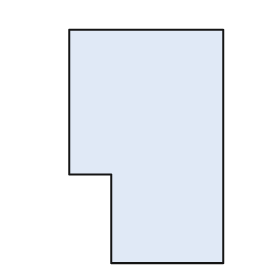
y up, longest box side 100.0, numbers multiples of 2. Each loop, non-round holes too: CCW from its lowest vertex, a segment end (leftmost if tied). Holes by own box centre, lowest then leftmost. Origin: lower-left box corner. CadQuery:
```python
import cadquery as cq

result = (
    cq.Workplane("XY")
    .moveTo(18.0, 0.0)
    .lineTo(66.0, 0.0)
    .lineTo(66.0, 100.0)
    .lineTo(0.0, 100.0)
    .lineTo(0.0, 38.0)
    .lineTo(18.0, 38.0)
    .close()
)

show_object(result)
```